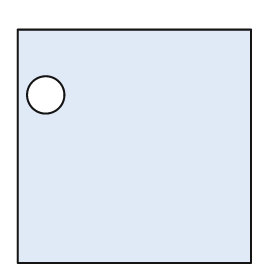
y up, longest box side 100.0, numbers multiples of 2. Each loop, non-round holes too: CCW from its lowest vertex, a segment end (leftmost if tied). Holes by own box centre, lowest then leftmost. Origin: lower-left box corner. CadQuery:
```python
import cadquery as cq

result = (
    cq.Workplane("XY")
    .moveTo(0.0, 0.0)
    .lineTo(100.0, 0.0)
    .lineTo(100.0, 100.0)
    .lineTo(0.0, 100.0)
    .close()
    .moveTo(12.0, 72.0)
    .circle(8.0)
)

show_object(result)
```